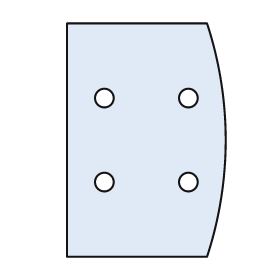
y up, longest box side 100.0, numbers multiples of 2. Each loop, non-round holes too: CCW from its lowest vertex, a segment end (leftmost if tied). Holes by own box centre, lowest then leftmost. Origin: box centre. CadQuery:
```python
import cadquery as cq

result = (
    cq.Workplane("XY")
    .moveTo(-34.0, -50.0)
    .lineTo(26.0, -50.0)
    .threePointArc((34.0, 0.0), (26.0, 50.0))
    .lineTo(-34.0, 50.0)
    .close()
    .moveTo(-18.0, -18.0)
    .circle(4.0)
    .moveTo(18.0, -18.0)
    .circle(4.0)
    .moveTo(-18.0, 18.0)
    .circle(4.0)
    .moveTo(18.0, 18.0)
    .circle(4.0)
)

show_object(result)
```